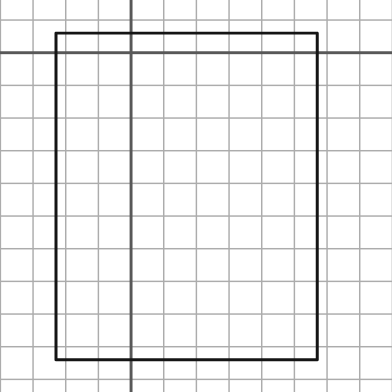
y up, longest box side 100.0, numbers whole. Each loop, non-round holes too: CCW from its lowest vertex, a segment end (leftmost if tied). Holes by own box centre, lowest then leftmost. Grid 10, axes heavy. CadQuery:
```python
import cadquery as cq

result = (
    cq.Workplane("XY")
    .moveTo(-23.0, -94.0)
    .lineTo(57.0, -94.0)
    .lineTo(57.0, 6.0)
    .lineTo(-23.0, 6.0)
    .close()
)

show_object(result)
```